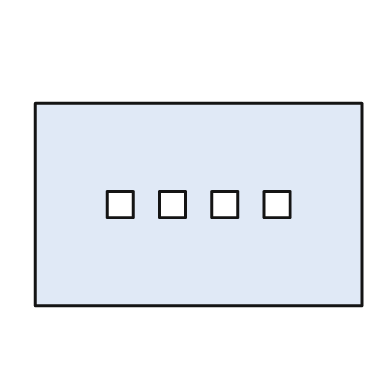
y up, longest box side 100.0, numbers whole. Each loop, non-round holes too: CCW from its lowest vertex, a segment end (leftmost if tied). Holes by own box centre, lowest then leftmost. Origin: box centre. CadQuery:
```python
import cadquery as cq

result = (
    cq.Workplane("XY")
    .moveTo(-50.0, -31.0)
    .lineTo(50.0, -31.0)
    .lineTo(50.0, 31.0)
    .lineTo(-50.0, 31.0)
    .close()
    .moveTo(-28.0, -4.0)
    .lineTo(-20.0, -4.0)
    .lineTo(-20.0, 4.0)
    .lineTo(-28.0, 4.0)
    .close()
    .moveTo(-12.0, -4.0)
    .lineTo(-4.0, -4.0)
    .lineTo(-4.0, 4.0)
    .lineTo(-12.0, 4.0)
    .close()
    .moveTo(4.0, -4.0)
    .lineTo(12.0, -4.0)
    .lineTo(12.0, 4.0)
    .lineTo(4.0, 4.0)
    .close()
    .moveTo(20.0, -4.0)
    .lineTo(28.0, -4.0)
    .lineTo(28.0, 4.0)
    .lineTo(20.0, 4.0)
    .close()
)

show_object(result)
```